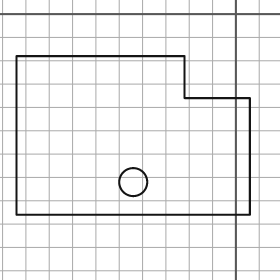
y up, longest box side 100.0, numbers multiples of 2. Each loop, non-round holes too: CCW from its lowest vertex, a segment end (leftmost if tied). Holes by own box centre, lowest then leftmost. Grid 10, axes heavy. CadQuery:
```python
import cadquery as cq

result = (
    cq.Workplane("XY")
    .moveTo(-94.0, -86.0)
    .lineTo(6.0, -86.0)
    .lineTo(6.0, -36.0)
    .lineTo(-22.0, -36.0)
    .lineTo(-22.0, -18.0)
    .lineTo(-94.0, -18.0)
    .close()
    .moveTo(-44.0, -72.0)
    .circle(6.0)
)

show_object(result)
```